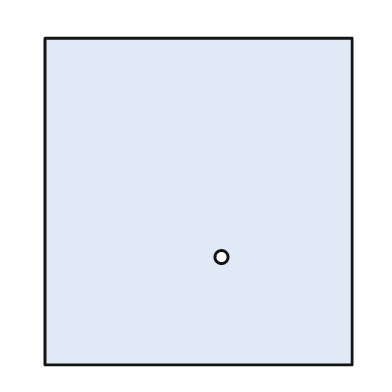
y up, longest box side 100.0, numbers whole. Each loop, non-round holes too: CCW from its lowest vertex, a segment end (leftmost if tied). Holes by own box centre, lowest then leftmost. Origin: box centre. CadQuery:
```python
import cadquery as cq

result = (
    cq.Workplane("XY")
    .moveTo(-47.0, -50.0)
    .lineTo(47.0, -50.0)
    .lineTo(47.0, 50.0)
    .lineTo(-47.0, 50.0)
    .close()
    .moveTo(7.0, -17.0)
    .circle(2.0)
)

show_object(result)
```